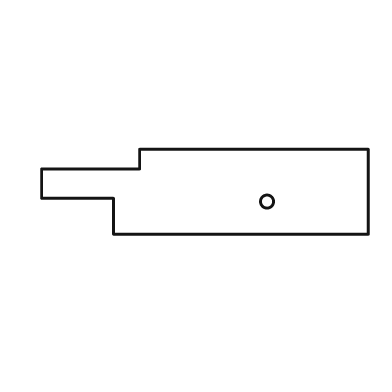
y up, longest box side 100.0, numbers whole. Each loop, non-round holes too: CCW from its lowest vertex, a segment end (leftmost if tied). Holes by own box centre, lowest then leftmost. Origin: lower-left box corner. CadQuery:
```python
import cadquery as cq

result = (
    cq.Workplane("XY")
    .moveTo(22.0, 0.0)
    .lineTo(100.0, 0.0)
    .lineTo(100.0, 26.0)
    .lineTo(30.0, 26.0)
    .lineTo(30.0, 20.0)
    .lineTo(0.0, 20.0)
    .lineTo(0.0, 11.0)
    .lineTo(22.0, 11.0)
    .close()
    .moveTo(69.0, 10.0)
    .circle(2.0)
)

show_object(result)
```